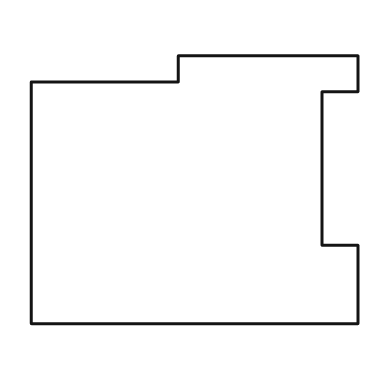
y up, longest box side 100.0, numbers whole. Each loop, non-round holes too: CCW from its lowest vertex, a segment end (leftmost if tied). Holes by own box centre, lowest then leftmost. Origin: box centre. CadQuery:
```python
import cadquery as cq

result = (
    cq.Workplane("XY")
    .moveTo(-50.0, -41.0)
    .lineTo(50.0, -41.0)
    .lineTo(50.0, -17.0)
    .lineTo(39.0, -17.0)
    .lineTo(39.0, 30.0)
    .lineTo(50.0, 30.0)
    .lineTo(50.0, 41.0)
    .lineTo(-5.0, 41.0)
    .lineTo(-5.0, 33.0)
    .lineTo(-50.0, 33.0)
    .close()
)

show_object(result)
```